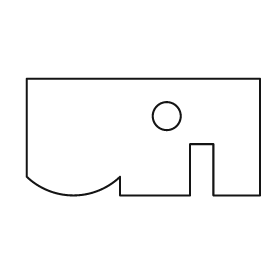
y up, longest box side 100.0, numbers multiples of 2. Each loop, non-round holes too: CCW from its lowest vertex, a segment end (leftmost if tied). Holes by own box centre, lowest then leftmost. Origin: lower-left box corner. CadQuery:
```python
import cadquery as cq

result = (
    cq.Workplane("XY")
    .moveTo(40.0, 0.0)
    .lineTo(70.0, 0.0)
    .lineTo(70.0, 22.0)
    .lineTo(80.0, 22.0)
    .lineTo(80.0, 0.0)
    .lineTo(100.0, 0.0)
    .lineTo(100.0, 50.0)
    .lineTo(0.0, 50.0)
    .lineTo(0.0, 8.0)
    .threePointArc((20.0, 0.0), (40.0, 8.0))
    .close()
    .moveTo(60.0, 34.0)
    .circle(6.0)
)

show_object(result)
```